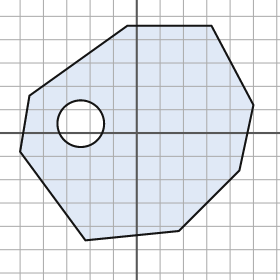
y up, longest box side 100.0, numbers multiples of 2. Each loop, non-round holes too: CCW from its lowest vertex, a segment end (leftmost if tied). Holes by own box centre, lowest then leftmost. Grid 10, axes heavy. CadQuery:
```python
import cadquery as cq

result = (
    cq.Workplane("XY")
    .moveTo(-22.0, -46.0)
    .lineTo(18.0, -42.0)
    .lineTo(44.0, -16.0)
    .lineTo(50.0, 12.0)
    .lineTo(32.0, 46.0)
    .lineTo(-4.0, 46.0)
    .lineTo(-46.0, 16.0)
    .lineTo(-50.0, -8.0)
    .close()
    .moveTo(-24.0, 4.0)
    .circle(10.0)
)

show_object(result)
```